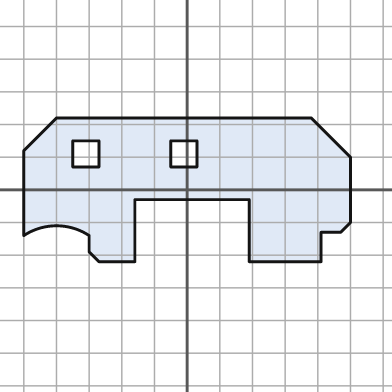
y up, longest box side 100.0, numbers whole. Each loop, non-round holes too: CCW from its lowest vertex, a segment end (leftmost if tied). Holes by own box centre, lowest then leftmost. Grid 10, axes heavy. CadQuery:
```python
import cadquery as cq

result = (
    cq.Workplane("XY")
    .moveTo(-27.0, -22.0)
    .lineTo(-16.0, -22.0)
    .lineTo(-16.0, -3.0)
    .lineTo(19.0, -3.0)
    .lineTo(19.0, -22.0)
    .lineTo(41.0, -22.0)
    .lineTo(41.0, -13.0)
    .lineTo(47.0, -13.0)
    .lineTo(50.0, -10.0)
    .lineTo(50.0, 10.0)
    .lineTo(38.0, 22.0)
    .lineTo(-40.0, 22.0)
    .lineTo(-50.0, 12.0)
    .lineTo(-50.0, -14.0)
    .threePointArc((-40.0, -11.0), (-30.0, -14.0))
    .lineTo(-30.0, -19.0)
    .close()
    .moveTo(-35.0, 7.0)
    .lineTo(-27.0, 7.0)
    .lineTo(-27.0, 15.0)
    .lineTo(-35.0, 15.0)
    .close()
    .moveTo(-5.0, 7.0)
    .lineTo(3.0, 7.0)
    .lineTo(3.0, 15.0)
    .lineTo(-5.0, 15.0)
    .close()
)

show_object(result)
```